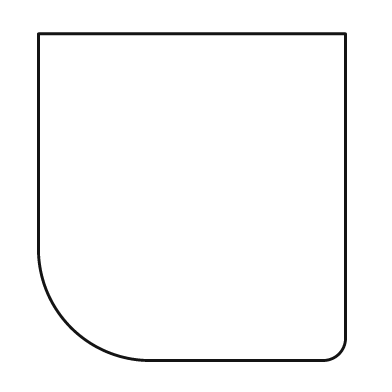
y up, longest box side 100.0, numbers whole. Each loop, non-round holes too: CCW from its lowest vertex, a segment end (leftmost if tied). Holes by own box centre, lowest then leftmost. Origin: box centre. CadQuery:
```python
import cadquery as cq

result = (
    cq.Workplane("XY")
    .moveTo(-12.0, -50.0)
    .lineTo(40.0, -50.0)
    .threePointArc((45.0, -48.0), (47.0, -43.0))
    .lineTo(47.0, 50.0)
    .lineTo(-47.0, 50.0)
    .lineTo(-47.0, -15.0)
    .threePointArc((-37.0, -40.0), (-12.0, -50.0))
    .close()
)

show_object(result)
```